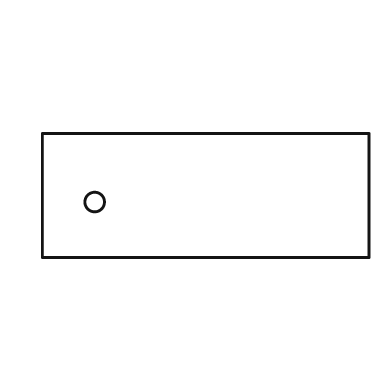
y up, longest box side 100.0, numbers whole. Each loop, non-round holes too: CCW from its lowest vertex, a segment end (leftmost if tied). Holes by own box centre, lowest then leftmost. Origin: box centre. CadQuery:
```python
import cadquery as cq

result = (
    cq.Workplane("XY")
    .moveTo(-50.0, -19.0)
    .lineTo(50.0, -19.0)
    .lineTo(50.0, 19.0)
    .lineTo(-50.0, 19.0)
    .close()
    .moveTo(-34.0, -2.0)
    .circle(3.0)
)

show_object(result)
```